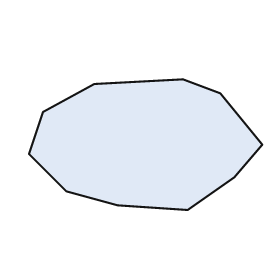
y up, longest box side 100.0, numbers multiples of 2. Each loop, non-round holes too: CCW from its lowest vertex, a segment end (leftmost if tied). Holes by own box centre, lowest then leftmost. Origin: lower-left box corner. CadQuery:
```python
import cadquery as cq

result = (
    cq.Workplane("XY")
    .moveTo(68.0, 0.0)
    .lineTo(88.0, 14.0)
    .lineTo(100.0, 28.0)
    .lineTo(82.0, 50.0)
    .lineTo(66.0, 56.0)
    .lineTo(28.0, 54.0)
    .lineTo(6.0, 42.0)
    .lineTo(0.0, 24.0)
    .lineTo(16.0, 8.0)
    .lineTo(38.0, 2.0)
    .close()
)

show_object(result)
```